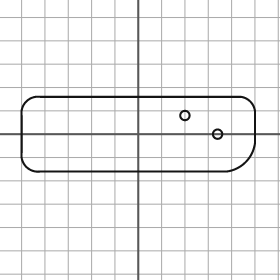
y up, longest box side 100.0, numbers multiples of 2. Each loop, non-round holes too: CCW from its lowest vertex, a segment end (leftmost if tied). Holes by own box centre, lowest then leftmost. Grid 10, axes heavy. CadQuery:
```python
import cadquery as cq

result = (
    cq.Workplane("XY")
    .moveTo(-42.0, -16.0)
    .lineTo(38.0, -16.0)
    .threePointArc((46.0, -12.0), (50.0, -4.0))
    .lineTo(50.0, 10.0)
    .threePointArc((48.0, 14.0), (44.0, 16.0))
    .lineTo(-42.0, 16.0)
    .threePointArc((-48.0, 14.0), (-50.0, 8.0))
    .lineTo(-50.0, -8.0)
    .threePointArc((-48.0, -14.0), (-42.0, -16.0))
    .close()
    .moveTo(34.0, 0.0)
    .circle(2.0)
    .moveTo(20.0, 8.0)
    .circle(2.0)
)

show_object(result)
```